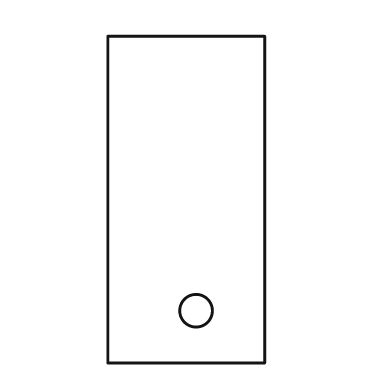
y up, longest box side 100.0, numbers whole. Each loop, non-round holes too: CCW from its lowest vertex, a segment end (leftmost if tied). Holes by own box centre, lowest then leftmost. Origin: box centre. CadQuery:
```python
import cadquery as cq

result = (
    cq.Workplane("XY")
    .moveTo(-24.0, -50.0)
    .lineTo(24.0, -50.0)
    .lineTo(24.0, 50.0)
    .lineTo(-24.0, 50.0)
    .close()
    .moveTo(3.0, -34.0)
    .circle(5.0)
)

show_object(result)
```